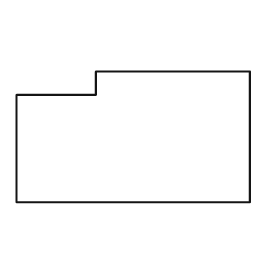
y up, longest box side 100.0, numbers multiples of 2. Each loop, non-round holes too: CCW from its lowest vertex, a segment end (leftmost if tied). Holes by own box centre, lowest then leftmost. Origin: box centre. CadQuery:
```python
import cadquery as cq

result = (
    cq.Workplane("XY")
    .moveTo(-50.0, -28.0)
    .lineTo(50.0, -28.0)
    .lineTo(50.0, 28.0)
    .lineTo(-16.0, 28.0)
    .lineTo(-16.0, 18.0)
    .lineTo(-50.0, 18.0)
    .close()
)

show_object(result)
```